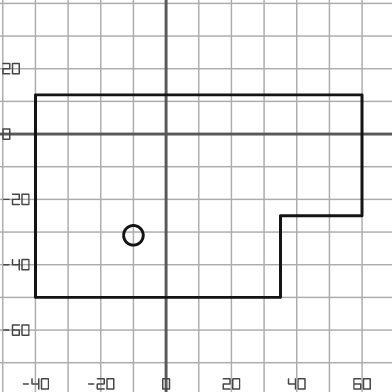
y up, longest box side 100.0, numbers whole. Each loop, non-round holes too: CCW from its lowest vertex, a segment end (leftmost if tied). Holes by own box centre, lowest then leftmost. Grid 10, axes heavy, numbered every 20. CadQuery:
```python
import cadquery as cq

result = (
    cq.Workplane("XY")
    .moveTo(-40.0, -50.0)
    .lineTo(35.0, -50.0)
    .lineTo(35.0, -25.0)
    .lineTo(60.0, -25.0)
    .lineTo(60.0, 12.0)
    .lineTo(-40.0, 12.0)
    .close()
    .moveTo(-10.0, -31.0)
    .circle(3.0)
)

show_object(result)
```